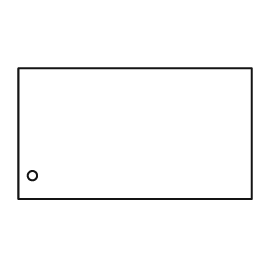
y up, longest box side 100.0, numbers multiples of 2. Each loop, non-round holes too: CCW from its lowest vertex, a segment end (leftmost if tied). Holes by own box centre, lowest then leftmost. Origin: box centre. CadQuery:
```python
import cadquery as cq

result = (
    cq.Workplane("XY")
    .moveTo(-50.0, -28.0)
    .lineTo(50.0, -28.0)
    .lineTo(50.0, 28.0)
    .lineTo(-50.0, 28.0)
    .close()
    .moveTo(-44.0, -18.0)
    .circle(2.0)
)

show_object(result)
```